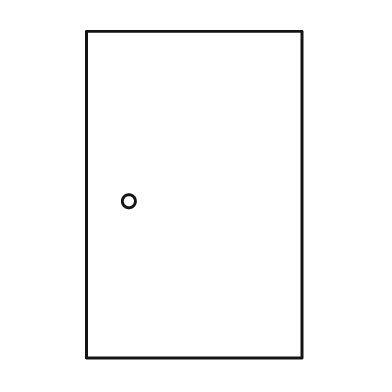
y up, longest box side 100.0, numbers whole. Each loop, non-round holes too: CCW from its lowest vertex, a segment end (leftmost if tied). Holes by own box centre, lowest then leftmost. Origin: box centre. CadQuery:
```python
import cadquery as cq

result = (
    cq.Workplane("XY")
    .moveTo(-33.0, -50.0)
    .lineTo(33.0, -50.0)
    .lineTo(33.0, 50.0)
    .lineTo(-33.0, 50.0)
    .close()
    .moveTo(-20.0, -2.0)
    .circle(2.0)
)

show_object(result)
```